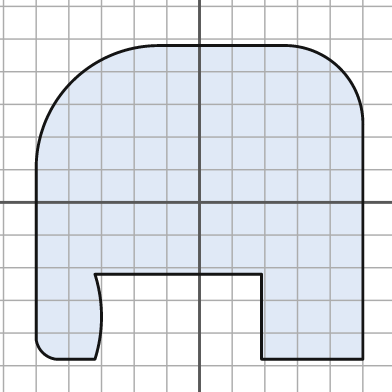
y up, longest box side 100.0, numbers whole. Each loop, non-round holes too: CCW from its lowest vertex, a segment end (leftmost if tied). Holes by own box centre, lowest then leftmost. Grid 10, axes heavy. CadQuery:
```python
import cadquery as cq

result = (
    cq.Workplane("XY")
    .moveTo(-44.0, -48.0)
    .lineTo(-32.0, -48.0)
    .threePointArc((-30.0, -35.0), (-32.0, -22.0))
    .lineTo(19.0, -22.0)
    .lineTo(19.0, -48.0)
    .lineTo(50.0, -48.0)
    .lineTo(50.0, 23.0)
    .threePointArc((43.0, 41.0), (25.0, 48.0))
    .lineTo(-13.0, 48.0)
    .threePointArc((-39.0, 37.0), (-50.0, 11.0))
    .lineTo(-50.0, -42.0)
    .threePointArc((-48.0, -46.0), (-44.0, -48.0))
    .close()
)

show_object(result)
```